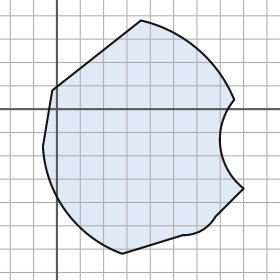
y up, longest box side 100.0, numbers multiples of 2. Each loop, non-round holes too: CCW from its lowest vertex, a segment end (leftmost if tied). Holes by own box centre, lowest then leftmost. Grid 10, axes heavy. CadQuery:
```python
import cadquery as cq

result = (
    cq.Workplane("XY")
    .moveTo(28.0, -62.0)
    .lineTo(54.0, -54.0)
    .threePointArc((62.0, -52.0), (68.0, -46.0))
    .lineTo(80.0, -34.0)
    .threePointArc((70.0, -16.0), (76.0, 4.0))
    .threePointArc((60.0, 26.0), (36.0, 38.0))
    .lineTo(-2.0, 8.0)
    .lineTo(-6.0, -16.0)
    .threePointArc((4.0, -44.0), (28.0, -62.0))
    .close()
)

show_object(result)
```